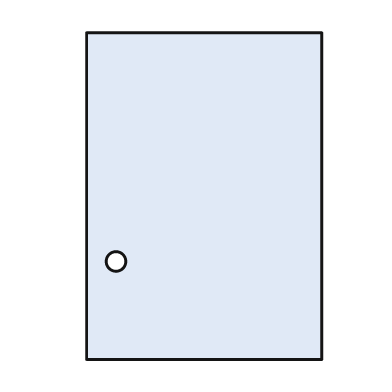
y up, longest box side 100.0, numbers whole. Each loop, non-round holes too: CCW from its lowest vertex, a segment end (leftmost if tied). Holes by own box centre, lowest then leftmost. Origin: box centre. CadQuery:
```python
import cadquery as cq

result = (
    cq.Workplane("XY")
    .moveTo(-36.0, -50.0)
    .lineTo(36.0, -50.0)
    .lineTo(36.0, 50.0)
    .lineTo(-36.0, 50.0)
    .close()
    .moveTo(-27.0, -20.0)
    .circle(3.0)
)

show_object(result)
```